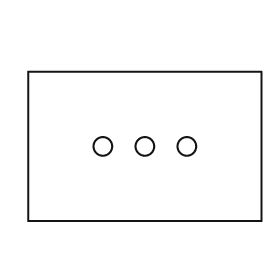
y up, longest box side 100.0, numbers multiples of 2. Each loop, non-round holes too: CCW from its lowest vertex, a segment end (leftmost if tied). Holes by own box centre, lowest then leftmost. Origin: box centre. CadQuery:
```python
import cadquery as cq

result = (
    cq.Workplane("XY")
    .moveTo(-50.0, -32.0)
    .lineTo(50.0, -32.0)
    .lineTo(50.0, 32.0)
    .lineTo(-50.0, 32.0)
    .close()
    .moveTo(-18.0, 0.0)
    .circle(4.0)
    .moveTo(0.0, 0.0)
    .circle(4.0)
    .moveTo(18.0, 0.0)
    .circle(4.0)
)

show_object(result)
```